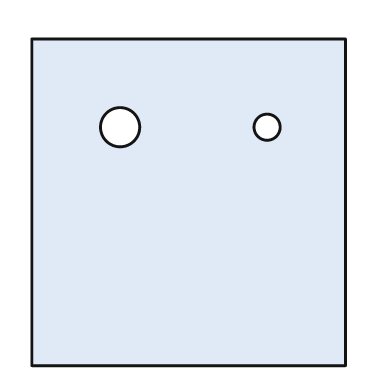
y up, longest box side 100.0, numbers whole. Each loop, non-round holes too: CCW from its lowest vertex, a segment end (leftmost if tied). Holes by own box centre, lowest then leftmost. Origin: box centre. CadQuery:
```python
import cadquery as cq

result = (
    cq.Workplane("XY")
    .moveTo(-48.0, -50.0)
    .lineTo(48.0, -50.0)
    .lineTo(48.0, 50.0)
    .lineTo(-48.0, 50.0)
    .close()
    .moveTo(-21.0, 23.0)
    .circle(6.0)
    .moveTo(24.0, 23.0)
    .circle(4.0)
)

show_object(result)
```